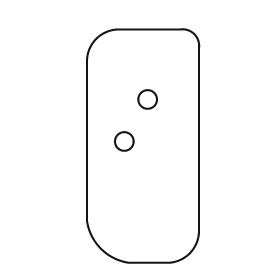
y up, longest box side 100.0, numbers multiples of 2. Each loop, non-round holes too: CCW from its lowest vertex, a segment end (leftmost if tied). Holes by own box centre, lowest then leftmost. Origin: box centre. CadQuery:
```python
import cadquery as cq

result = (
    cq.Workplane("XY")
    .moveTo(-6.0, -50.0)
    .lineTo(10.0, -50.0)
    .threePointArc((20.0, -46.0), (24.0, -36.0))
    .lineTo(24.0, 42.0)
    .threePointArc((22.0, 48.0), (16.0, 50.0))
    .lineTo(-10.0, 50.0)
    .threePointArc((-20.0, 46.0), (-24.0, 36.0))
    .lineTo(-24.0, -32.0)
    .threePointArc((-18.0, -44.0), (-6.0, -50.0))
    .close()
    .moveTo(-8.0, 2.0)
    .circle(4.0)
    .moveTo(2.0, 20.0)
    .circle(4.0)
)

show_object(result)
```